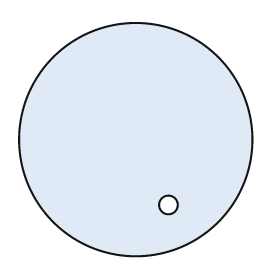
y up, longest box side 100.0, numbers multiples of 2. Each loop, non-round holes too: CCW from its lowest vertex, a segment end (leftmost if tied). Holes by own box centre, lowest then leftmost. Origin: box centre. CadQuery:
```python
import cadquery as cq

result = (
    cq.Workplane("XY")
    .moveTo(0.0, 0.0)
    .circle(50.0)
    .moveTo(14.0, -28.0)
    .circle(4.0)
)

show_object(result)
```